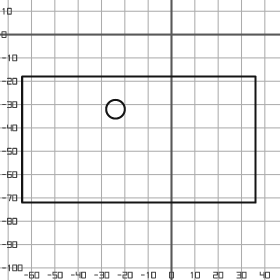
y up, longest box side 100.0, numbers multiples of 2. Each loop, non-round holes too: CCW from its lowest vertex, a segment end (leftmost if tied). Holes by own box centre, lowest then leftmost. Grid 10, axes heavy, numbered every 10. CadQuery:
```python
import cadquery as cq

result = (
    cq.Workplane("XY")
    .moveTo(-64.0, -72.0)
    .lineTo(36.0, -72.0)
    .lineTo(36.0, -18.0)
    .lineTo(-64.0, -18.0)
    .close()
    .moveTo(-24.0, -32.0)
    .circle(4.0)
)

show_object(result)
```